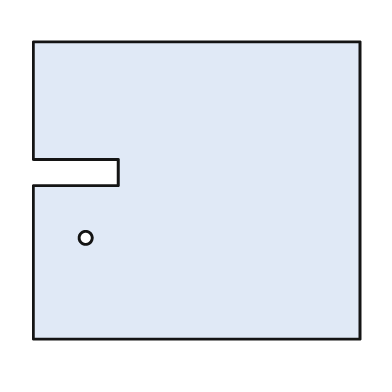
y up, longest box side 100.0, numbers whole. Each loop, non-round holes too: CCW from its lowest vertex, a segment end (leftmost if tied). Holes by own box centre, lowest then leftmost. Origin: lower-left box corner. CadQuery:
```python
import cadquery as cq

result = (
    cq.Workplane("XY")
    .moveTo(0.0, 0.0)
    .lineTo(100.0, 0.0)
    .lineTo(100.0, 91.0)
    .lineTo(0.0, 91.0)
    .lineTo(0.0, 55.0)
    .lineTo(26.0, 55.0)
    .lineTo(26.0, 47.0)
    .lineTo(0.0, 47.0)
    .close()
    .moveTo(16.0, 31.0)
    .circle(2.0)
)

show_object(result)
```